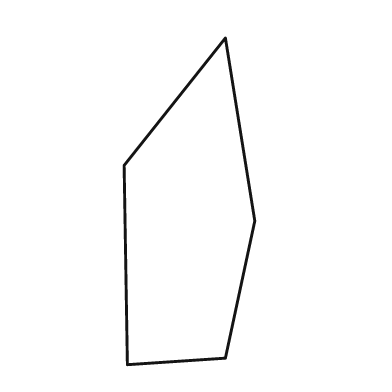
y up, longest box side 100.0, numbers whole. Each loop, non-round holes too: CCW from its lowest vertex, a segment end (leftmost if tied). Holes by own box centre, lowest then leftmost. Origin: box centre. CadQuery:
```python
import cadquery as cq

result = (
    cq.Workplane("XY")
    .moveTo(-19.0, -50.0)
    .lineTo(11.0, -48.0)
    .lineTo(20.0, -6.0)
    .lineTo(11.0, 50.0)
    .lineTo(-20.0, 11.0)
    .close()
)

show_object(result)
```